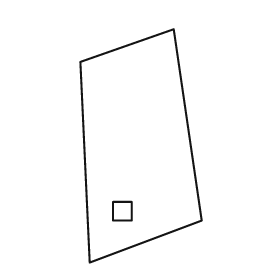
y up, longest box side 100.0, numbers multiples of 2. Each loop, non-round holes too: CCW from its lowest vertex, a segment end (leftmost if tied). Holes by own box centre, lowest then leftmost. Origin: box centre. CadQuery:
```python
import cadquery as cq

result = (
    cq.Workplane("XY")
    .moveTo(-22.0, -50.0)
    .lineTo(26.0, -32.0)
    .lineTo(14.0, 50.0)
    .lineTo(-26.0, 36.0)
    .close()
    .moveTo(-12.0, -32.0)
    .lineTo(-4.0, -32.0)
    .lineTo(-4.0, -24.0)
    .lineTo(-12.0, -24.0)
    .close()
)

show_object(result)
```